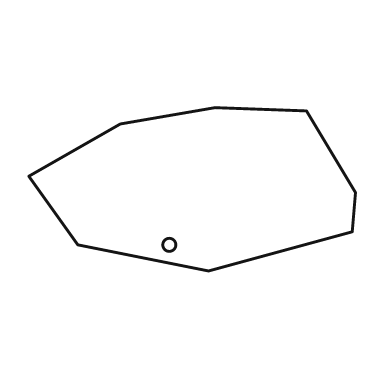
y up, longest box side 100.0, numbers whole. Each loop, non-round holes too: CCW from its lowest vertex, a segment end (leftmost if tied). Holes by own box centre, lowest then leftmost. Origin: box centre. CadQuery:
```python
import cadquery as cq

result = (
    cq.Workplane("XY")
    .moveTo(5.0, -25.0)
    .lineTo(49.0, -13.0)
    .lineTo(50.0, -1.0)
    .lineTo(35.0, 24.0)
    .lineTo(7.0, 25.0)
    .lineTo(-22.0, 20.0)
    .lineTo(-50.0, 4.0)
    .lineTo(-35.0, -17.0)
    .close()
    .moveTo(-7.0, -17.0)
    .circle(2.0)
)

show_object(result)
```